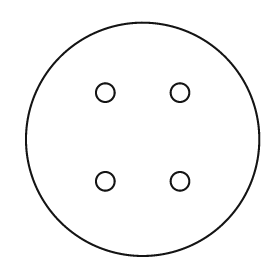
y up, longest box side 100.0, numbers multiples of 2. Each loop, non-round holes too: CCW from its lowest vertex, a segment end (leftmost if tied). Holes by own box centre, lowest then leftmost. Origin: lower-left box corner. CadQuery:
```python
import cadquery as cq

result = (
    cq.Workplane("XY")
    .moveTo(50.0, 50.0)
    .circle(50.0)
    .moveTo(34.0, 32.0)
    .circle(4.0)
    .moveTo(66.0, 32.0)
    .circle(4.0)
    .moveTo(34.0, 70.0)
    .circle(4.0)
    .moveTo(66.0, 70.0)
    .circle(4.0)
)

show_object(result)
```